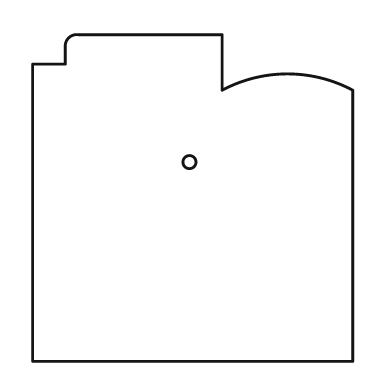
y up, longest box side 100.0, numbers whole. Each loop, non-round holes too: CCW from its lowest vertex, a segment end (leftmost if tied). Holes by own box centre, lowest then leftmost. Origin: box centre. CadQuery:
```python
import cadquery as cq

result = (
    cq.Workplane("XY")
    .moveTo(-49.0, -50.0)
    .lineTo(49.0, -50.0)
    .lineTo(49.0, 33.0)
    .threePointArc((29.0, 38.0), (9.0, 33.0))
    .lineTo(9.0, 50.0)
    .lineTo(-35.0, 50.0)
    .threePointArc((-38.0, 49.0), (-39.0, 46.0))
    .lineTo(-39.0, 41.0)
    .lineTo(-49.0, 41.0)
    .close()
    .moveTo(-1.0, 11.0)
    .circle(2.0)
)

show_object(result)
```